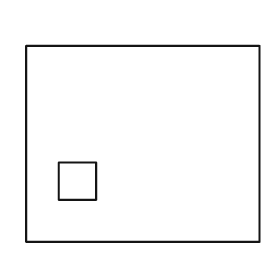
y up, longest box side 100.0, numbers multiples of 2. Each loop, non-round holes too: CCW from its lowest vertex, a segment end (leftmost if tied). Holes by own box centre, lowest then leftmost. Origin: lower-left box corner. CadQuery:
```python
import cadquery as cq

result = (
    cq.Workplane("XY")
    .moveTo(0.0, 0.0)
    .lineTo(100.0, 0.0)
    .lineTo(100.0, 84.0)
    .lineTo(0.0, 84.0)
    .close()
    .moveTo(14.0, 18.0)
    .lineTo(30.0, 18.0)
    .lineTo(30.0, 34.0)
    .lineTo(14.0, 34.0)
    .close()
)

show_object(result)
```